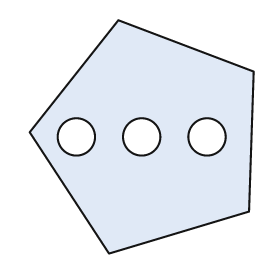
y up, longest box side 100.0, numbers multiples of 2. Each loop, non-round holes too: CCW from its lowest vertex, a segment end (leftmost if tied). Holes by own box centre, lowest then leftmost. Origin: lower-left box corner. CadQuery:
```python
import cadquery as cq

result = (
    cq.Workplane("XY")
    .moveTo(34.0, 0.0)
    .lineTo(94.0, 18.0)
    .lineTo(96.0, 78.0)
    .lineTo(38.0, 100.0)
    .lineTo(0.0, 52.0)
    .close()
    .moveTo(20.0, 50.0)
    .circle(8.0)
    .moveTo(48.0, 50.0)
    .circle(8.0)
    .moveTo(76.0, 50.0)
    .circle(8.0)
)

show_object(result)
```